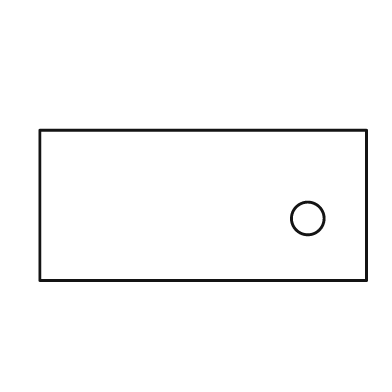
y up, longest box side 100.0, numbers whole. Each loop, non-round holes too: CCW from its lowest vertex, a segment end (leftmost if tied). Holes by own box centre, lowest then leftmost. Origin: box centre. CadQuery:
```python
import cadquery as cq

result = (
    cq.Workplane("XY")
    .moveTo(-50.0, -23.0)
    .lineTo(50.0, -23.0)
    .lineTo(50.0, 23.0)
    .lineTo(-50.0, 23.0)
    .close()
    .moveTo(32.0, -4.0)
    .circle(5.0)
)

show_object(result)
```